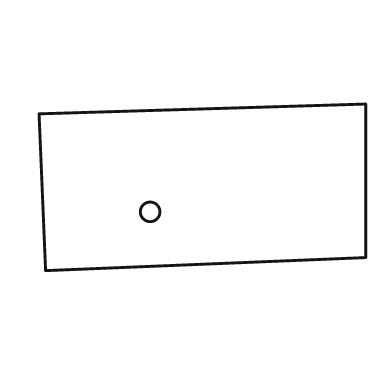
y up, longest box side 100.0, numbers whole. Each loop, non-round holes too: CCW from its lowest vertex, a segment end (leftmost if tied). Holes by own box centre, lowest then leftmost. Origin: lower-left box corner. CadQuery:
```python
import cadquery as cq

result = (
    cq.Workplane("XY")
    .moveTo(2.0, 0.0)
    .lineTo(100.0, 4.0)
    .lineTo(100.0, 51.0)
    .lineTo(0.0, 48.0)
    .close()
    .moveTo(34.0, 18.0)
    .circle(3.0)
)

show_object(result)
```